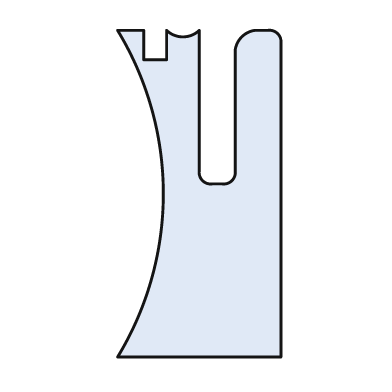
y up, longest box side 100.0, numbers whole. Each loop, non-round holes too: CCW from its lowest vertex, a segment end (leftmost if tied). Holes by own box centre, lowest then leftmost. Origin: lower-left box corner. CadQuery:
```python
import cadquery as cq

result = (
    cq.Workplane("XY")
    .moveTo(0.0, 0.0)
    .lineTo(50.0, 0.0)
    .lineTo(50.0, 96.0)
    .threePointArc((49.0, 99.0), (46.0, 100.0))
    .lineTo(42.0, 100.0)
    .threePointArc((38.0, 98.0), (36.0, 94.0))
    .lineTo(36.0, 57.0)
    .threePointArc((35.0, 54.0), (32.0, 53.0))
    .lineTo(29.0, 53.0)
    .threePointArc((26.0, 54.0), (25.0, 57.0))
    .lineTo(25.0, 100.0)
    .threePointArc((20.0, 98.0), (15.0, 100.0))
    .lineTo(15.0, 91.0)
    .lineTo(8.0, 91.0)
    .lineTo(8.0, 100.0)
    .lineTo(0.0, 100.0)
    .threePointArc((14.0, 50.0), (0.0, 0.0))
    .close()
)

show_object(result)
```